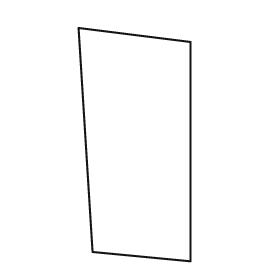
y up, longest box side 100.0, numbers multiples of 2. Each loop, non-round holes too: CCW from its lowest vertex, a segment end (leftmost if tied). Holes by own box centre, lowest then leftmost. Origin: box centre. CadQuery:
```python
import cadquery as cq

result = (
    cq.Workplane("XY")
    .moveTo(24.0, -50.0)
    .lineTo(24.0, 44.0)
    .lineTo(-24.0, 50.0)
    .lineTo(-18.0, -46.0)
    .close()
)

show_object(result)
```